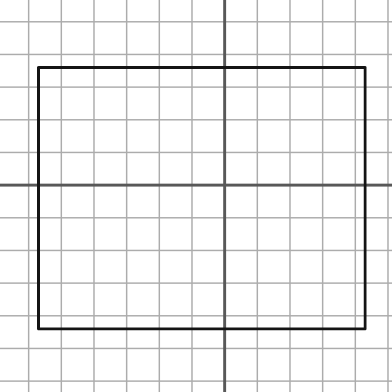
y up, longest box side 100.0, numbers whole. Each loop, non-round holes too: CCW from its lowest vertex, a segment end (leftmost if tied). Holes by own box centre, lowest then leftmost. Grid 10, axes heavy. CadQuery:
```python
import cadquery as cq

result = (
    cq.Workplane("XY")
    .moveTo(-57.0, -44.0)
    .lineTo(43.0, -44.0)
    .lineTo(43.0, 36.0)
    .lineTo(-57.0, 36.0)
    .close()
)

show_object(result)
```